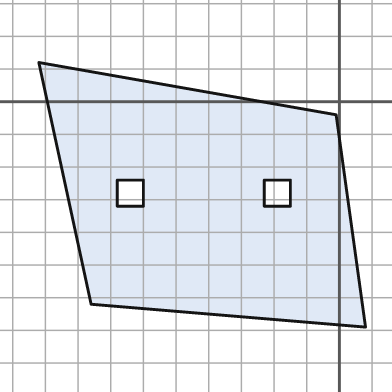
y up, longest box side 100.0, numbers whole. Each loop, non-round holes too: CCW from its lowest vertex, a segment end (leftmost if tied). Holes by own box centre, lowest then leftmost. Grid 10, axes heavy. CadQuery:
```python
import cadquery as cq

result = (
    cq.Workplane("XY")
    .moveTo(8.0, -69.0)
    .lineTo(-1.0, -4.0)
    .lineTo(-92.0, 12.0)
    .lineTo(-76.0, -62.0)
    .close()
    .moveTo(-68.0, -32.0)
    .lineTo(-60.0, -32.0)
    .lineTo(-60.0, -24.0)
    .lineTo(-68.0, -24.0)
    .close()
    .moveTo(-23.0, -32.0)
    .lineTo(-15.0, -32.0)
    .lineTo(-15.0, -24.0)
    .lineTo(-23.0, -24.0)
    .close()
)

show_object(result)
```